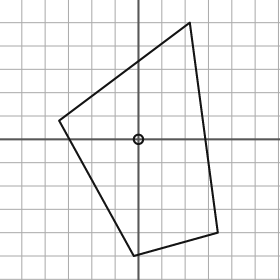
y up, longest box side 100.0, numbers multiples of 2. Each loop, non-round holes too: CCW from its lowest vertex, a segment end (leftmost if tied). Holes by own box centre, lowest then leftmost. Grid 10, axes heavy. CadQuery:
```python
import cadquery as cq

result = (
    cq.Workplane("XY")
    .moveTo(-2.0, -50.0)
    .lineTo(34.0, -40.0)
    .lineTo(22.0, 50.0)
    .lineTo(-34.0, 8.0)
    .close()
    .moveTo(0.0, 0.0)
    .circle(2.0)
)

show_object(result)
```